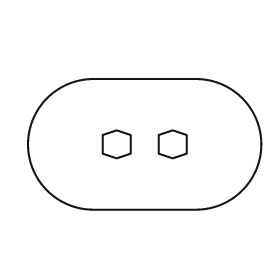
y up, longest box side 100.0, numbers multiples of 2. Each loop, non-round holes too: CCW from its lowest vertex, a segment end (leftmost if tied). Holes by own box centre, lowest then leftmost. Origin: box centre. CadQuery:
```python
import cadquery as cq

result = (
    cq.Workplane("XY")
    .moveTo(-22.0, -28.0)
    .lineTo(22.0, -28.0)
    .threePointArc((50.0, 0.0), (22.0, 28.0))
    .lineTo(-22.0, 28.0)
    .threePointArc((-50.0, 0.0), (-22.0, -28.0))
    .close()
    .moveTo(-12.0, -6.0)
    .lineTo(-6.0, -4.0)
    .lineTo(-6.0, 4.0)
    .lineTo(-12.0, 6.0)
    .lineTo(-18.0, 4.0)
    .lineTo(-18.0, -4.0)
    .close()
    .moveTo(12.0, -6.0)
    .lineTo(18.0, -4.0)
    .lineTo(18.0, 4.0)
    .lineTo(12.0, 6.0)
    .lineTo(6.0, 4.0)
    .lineTo(6.0, -4.0)
    .close()
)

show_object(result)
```